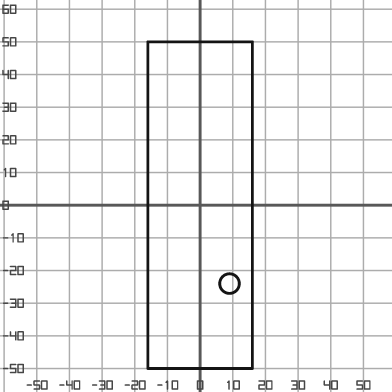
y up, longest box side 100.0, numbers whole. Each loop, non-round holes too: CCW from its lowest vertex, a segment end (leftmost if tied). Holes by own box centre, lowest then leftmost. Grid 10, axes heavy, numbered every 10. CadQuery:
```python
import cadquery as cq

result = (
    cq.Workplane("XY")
    .moveTo(-16.0, -50.0)
    .lineTo(16.0, -50.0)
    .lineTo(16.0, 50.0)
    .lineTo(-16.0, 50.0)
    .close()
    .moveTo(9.0, -24.0)
    .circle(3.0)
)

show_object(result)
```